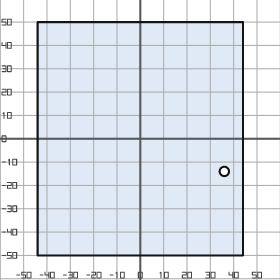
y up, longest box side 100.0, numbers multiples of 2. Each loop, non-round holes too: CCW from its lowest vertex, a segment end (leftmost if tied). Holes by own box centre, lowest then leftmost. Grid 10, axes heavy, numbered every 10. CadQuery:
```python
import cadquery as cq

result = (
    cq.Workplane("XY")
    .moveTo(-44.0, -50.0)
    .lineTo(44.0, -50.0)
    .lineTo(44.0, 50.0)
    .lineTo(-44.0, 50.0)
    .close()
    .moveTo(36.0, -14.0)
    .circle(2.0)
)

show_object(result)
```